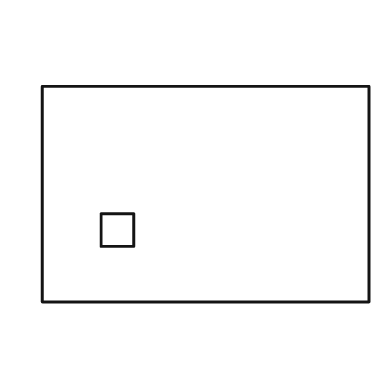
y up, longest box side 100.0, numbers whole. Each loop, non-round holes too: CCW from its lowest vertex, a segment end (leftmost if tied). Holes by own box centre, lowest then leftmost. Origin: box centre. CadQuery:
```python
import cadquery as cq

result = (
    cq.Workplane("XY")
    .moveTo(-50.0, -33.0)
    .lineTo(50.0, -33.0)
    .lineTo(50.0, 33.0)
    .lineTo(-50.0, 33.0)
    .close()
    .moveTo(-32.0, -16.0)
    .lineTo(-22.0, -16.0)
    .lineTo(-22.0, -6.0)
    .lineTo(-32.0, -6.0)
    .close()
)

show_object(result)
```